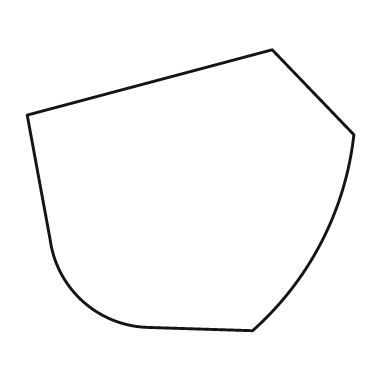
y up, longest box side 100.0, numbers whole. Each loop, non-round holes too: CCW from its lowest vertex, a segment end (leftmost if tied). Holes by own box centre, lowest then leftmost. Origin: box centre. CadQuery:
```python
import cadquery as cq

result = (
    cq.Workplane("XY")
    .moveTo(19.0, -43.0)
    .threePointArc((40.0, -16.0), (50.0, 17.0))
    .lineTo(25.0, 43.0)
    .lineTo(-50.0, 23.0)
    .lineTo(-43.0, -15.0)
    .threePointArc((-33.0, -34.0), (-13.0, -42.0))
    .close()
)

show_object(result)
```